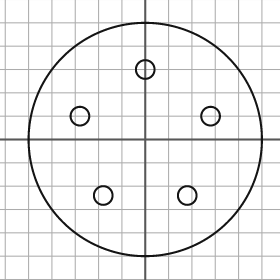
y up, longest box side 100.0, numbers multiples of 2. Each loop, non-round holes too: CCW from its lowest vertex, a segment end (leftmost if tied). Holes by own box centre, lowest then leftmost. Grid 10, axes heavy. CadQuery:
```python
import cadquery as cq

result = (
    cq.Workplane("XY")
    .moveTo(0.0, 0.0)
    .circle(50.0)
    .moveTo(-18.0, -24.0)
    .circle(4.0)
    .moveTo(18.0, -24.0)
    .circle(4.0)
    .moveTo(-28.0, 10.0)
    .circle(4.0)
    .moveTo(28.0, 10.0)
    .circle(4.0)
    .moveTo(0.0, 30.0)
    .circle(4.0)
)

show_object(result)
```